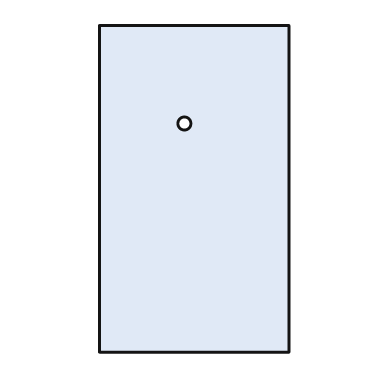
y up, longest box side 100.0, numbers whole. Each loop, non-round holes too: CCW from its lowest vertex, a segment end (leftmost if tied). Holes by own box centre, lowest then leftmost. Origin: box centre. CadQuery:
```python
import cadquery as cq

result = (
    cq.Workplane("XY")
    .moveTo(-29.0, -50.0)
    .lineTo(29.0, -50.0)
    .lineTo(29.0, 50.0)
    .lineTo(-29.0, 50.0)
    .close()
    .moveTo(-3.0, 20.0)
    .circle(2.0)
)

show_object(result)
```